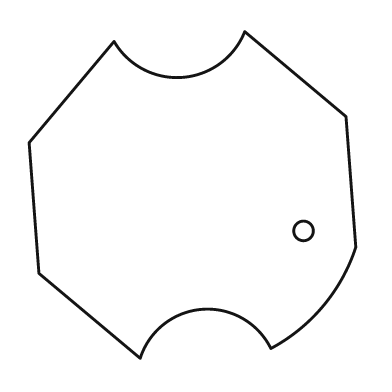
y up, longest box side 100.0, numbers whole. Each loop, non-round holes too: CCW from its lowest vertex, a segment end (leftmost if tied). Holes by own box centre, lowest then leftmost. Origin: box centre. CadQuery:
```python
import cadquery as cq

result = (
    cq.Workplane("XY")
    .moveTo(-16.0, -50.0)
    .threePointArc((3.0, -35.0), (24.0, -47.0))
    .threePointArc((40.0, -34.0), (50.0, -16.0))
    .lineTo(47.0, 24.0)
    .lineTo(16.0, 50.0)
    .threePointArc((-3.0, 36.0), (-24.0, 47.0))
    .lineTo(-50.0, 16.0)
    .lineTo(-47.0, -24.0)
    .close()
    .moveTo(34.0, -11.0)
    .circle(3.0)
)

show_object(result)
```